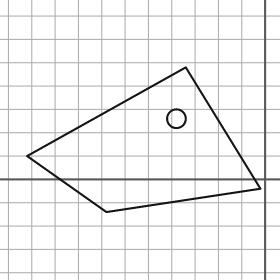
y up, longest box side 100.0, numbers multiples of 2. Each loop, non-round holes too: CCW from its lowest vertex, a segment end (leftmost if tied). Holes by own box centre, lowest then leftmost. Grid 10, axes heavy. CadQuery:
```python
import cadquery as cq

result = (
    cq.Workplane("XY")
    .moveTo(-68.0, -14.0)
    .lineTo(-2.0, -4.0)
    .lineTo(-34.0, 48.0)
    .lineTo(-102.0, 10.0)
    .close()
    .moveTo(-38.0, 26.0)
    .circle(4.0)
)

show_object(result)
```